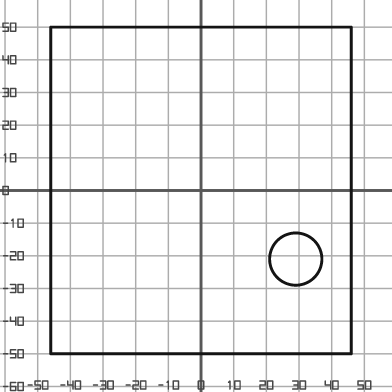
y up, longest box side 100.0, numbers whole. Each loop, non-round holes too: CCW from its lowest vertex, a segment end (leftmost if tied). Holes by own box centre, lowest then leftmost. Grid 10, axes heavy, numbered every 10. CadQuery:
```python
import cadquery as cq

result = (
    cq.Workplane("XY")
    .moveTo(-46.0, -50.0)
    .lineTo(46.0, -50.0)
    .lineTo(46.0, 50.0)
    .lineTo(-46.0, 50.0)
    .close()
    .moveTo(29.0, -21.0)
    .circle(8.0)
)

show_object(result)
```